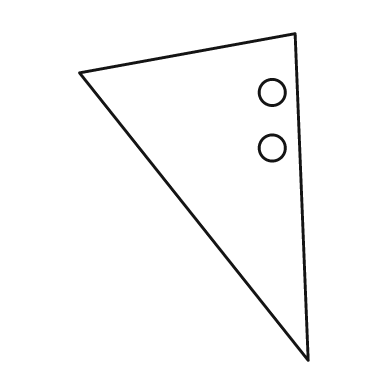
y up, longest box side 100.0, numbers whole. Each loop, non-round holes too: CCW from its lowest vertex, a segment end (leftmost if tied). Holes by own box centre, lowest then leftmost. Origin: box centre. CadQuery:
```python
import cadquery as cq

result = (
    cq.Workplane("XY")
    .moveTo(35.0, -50.0)
    .lineTo(31.0, 50.0)
    .lineTo(-35.0, 38.0)
    .close()
    .moveTo(24.0, 15.0)
    .circle(4.0)
    .moveTo(24.0, 32.0)
    .circle(4.0)
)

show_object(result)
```